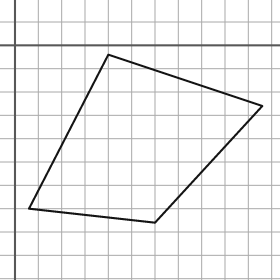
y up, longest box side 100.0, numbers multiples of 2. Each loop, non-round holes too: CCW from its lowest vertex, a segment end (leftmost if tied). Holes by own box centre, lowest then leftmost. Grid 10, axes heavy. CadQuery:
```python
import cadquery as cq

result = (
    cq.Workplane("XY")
    .moveTo(60.0, -76.0)
    .lineTo(106.0, -26.0)
    .lineTo(40.0, -4.0)
    .lineTo(6.0, -70.0)
    .close()
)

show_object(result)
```